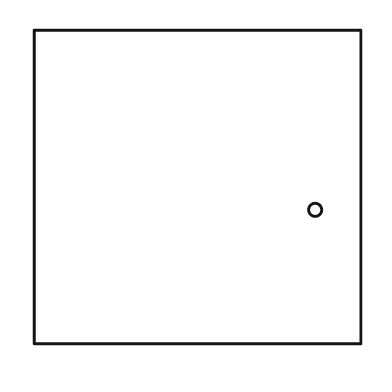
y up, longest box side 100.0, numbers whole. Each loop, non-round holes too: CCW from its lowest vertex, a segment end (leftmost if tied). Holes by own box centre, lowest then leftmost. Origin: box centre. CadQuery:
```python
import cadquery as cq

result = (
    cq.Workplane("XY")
    .moveTo(-50.0, -48.0)
    .lineTo(50.0, -48.0)
    .lineTo(50.0, 48.0)
    .lineTo(-50.0, 48.0)
    .close()
    .moveTo(36.0, -7.0)
    .circle(2.0)
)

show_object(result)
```